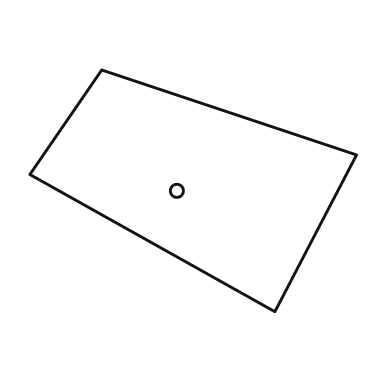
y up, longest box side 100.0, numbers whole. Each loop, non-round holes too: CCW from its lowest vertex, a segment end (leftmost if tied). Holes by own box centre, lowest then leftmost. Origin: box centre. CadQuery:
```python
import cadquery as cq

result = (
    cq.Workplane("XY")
    .moveTo(25.0, -37.0)
    .lineTo(50.0, 11.0)
    .lineTo(-28.0, 37.0)
    .lineTo(-50.0, 5.0)
    .close()
    .moveTo(-5.0, 0.0)
    .circle(2.0)
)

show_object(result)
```